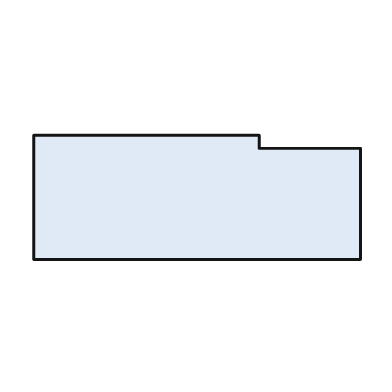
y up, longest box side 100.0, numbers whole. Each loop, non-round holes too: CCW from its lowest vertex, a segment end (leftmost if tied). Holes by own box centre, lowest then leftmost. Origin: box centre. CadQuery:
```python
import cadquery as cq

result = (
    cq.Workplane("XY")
    .moveTo(-50.0, -19.0)
    .lineTo(50.0, -19.0)
    .lineTo(50.0, 15.0)
    .lineTo(19.0, 15.0)
    .lineTo(19.0, 19.0)
    .lineTo(-50.0, 19.0)
    .close()
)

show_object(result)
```